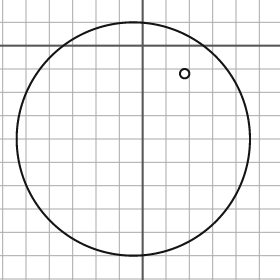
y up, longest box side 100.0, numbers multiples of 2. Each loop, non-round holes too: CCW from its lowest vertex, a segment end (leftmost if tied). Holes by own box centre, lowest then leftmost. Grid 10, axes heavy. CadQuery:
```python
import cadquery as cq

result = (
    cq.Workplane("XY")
    .moveTo(-4.0, -40.0)
    .circle(50.0)
    .moveTo(18.0, -12.0)
    .circle(2.0)
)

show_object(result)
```